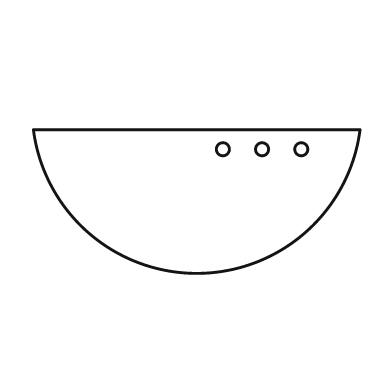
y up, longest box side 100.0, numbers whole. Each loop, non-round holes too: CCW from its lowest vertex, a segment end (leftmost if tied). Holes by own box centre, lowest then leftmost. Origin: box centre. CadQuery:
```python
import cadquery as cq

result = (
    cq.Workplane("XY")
    .moveTo(-50.0, 22.0)
    .threePointArc((0.0, -22.0), (50.0, 22.0))
    .close()
    .moveTo(8.0, 16.0)
    .circle(2.0)
    .moveTo(20.0, 16.0)
    .circle(2.0)
    .moveTo(32.0, 16.0)
    .circle(2.0)
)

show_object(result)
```